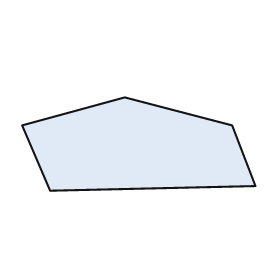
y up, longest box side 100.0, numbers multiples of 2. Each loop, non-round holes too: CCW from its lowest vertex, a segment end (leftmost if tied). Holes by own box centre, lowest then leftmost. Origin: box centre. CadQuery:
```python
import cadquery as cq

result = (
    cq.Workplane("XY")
    .moveTo(-38.0, -20.0)
    .lineTo(50.0, -18.0)
    .lineTo(40.0, 8.0)
    .lineTo(-6.0, 20.0)
    .lineTo(-50.0, 8.0)
    .close()
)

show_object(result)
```